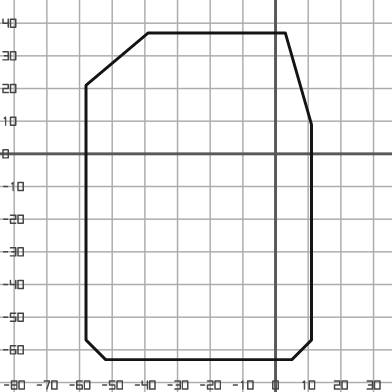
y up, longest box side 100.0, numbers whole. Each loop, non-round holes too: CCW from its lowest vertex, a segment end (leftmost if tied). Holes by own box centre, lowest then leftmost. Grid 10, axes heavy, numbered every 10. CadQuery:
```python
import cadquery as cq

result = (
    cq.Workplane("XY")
    .moveTo(-52.0, -63.0)
    .lineTo(5.0, -63.0)
    .lineTo(11.0, -57.0)
    .lineTo(11.0, 9.0)
    .lineTo(3.0, 37.0)
    .lineTo(-39.0, 37.0)
    .lineTo(-58.0, 21.0)
    .lineTo(-58.0, -57.0)
    .close()
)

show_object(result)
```